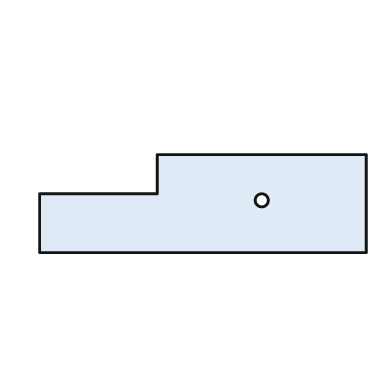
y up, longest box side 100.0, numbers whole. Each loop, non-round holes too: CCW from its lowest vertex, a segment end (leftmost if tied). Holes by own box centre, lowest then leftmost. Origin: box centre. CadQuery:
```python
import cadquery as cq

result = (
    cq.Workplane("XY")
    .moveTo(-50.0, -15.0)
    .lineTo(50.0, -15.0)
    .lineTo(50.0, 15.0)
    .lineTo(-14.0, 15.0)
    .lineTo(-14.0, 3.0)
    .lineTo(-50.0, 3.0)
    .close()
    .moveTo(18.0, 1.0)
    .circle(2.0)
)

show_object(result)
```